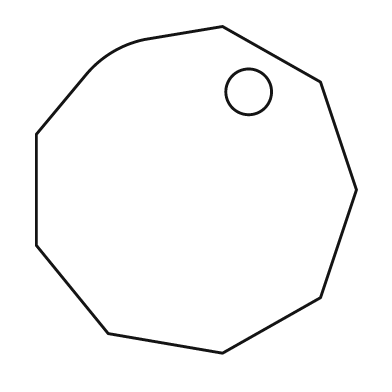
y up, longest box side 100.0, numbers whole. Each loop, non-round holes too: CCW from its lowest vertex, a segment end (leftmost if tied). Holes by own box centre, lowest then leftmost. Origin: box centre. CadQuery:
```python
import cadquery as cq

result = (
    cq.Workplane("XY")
    .moveTo(8.0, -50.0)
    .lineTo(38.0, -33.0)
    .lineTo(49.0, 0.0)
    .lineTo(38.0, 33.0)
    .lineTo(8.0, 50.0)
    .lineTo(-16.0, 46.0)
    .threePointArc((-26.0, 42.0), (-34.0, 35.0))
    .lineTo(-49.0, 17.0)
    .lineTo(-49.0, -17.0)
    .lineTo(-27.0, -44.0)
    .close()
    .moveTo(16.0, 30.0)
    .circle(7.0)
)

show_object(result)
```